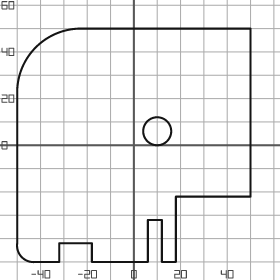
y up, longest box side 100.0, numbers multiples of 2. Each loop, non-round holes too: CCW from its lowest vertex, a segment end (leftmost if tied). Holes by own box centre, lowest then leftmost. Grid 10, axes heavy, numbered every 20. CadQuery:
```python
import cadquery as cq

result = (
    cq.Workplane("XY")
    .moveTo(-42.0, -50.0)
    .lineTo(-32.0, -50.0)
    .lineTo(-32.0, -42.0)
    .lineTo(-18.0, -42.0)
    .lineTo(-18.0, -50.0)
    .lineTo(6.0, -50.0)
    .lineTo(6.0, -32.0)
    .lineTo(12.0, -32.0)
    .lineTo(12.0, -50.0)
    .lineTo(18.0, -50.0)
    .lineTo(18.0, -22.0)
    .lineTo(50.0, -22.0)
    .lineTo(50.0, 50.0)
    .lineTo(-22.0, 50.0)
    .threePointArc((-42.0, 42.0), (-50.0, 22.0))
    .lineTo(-50.0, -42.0)
    .threePointArc((-48.0, -48.0), (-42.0, -50.0))
    .close()
    .moveTo(10.0, 6.0)
    .circle(6.0)
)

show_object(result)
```